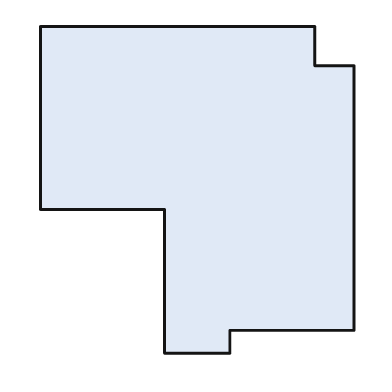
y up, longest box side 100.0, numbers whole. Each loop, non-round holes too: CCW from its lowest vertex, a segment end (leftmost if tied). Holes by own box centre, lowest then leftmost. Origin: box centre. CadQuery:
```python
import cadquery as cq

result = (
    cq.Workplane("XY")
    .moveTo(-10.0, -50.0)
    .lineTo(10.0, -50.0)
    .lineTo(10.0, -43.0)
    .lineTo(48.0, -43.0)
    .lineTo(48.0, 38.0)
    .lineTo(36.0, 38.0)
    .lineTo(36.0, 50.0)
    .lineTo(-48.0, 50.0)
    .lineTo(-48.0, -6.0)
    .lineTo(-10.0, -6.0)
    .close()
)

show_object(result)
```